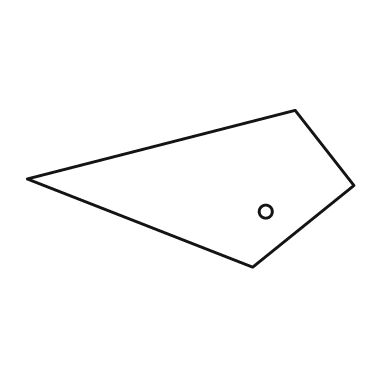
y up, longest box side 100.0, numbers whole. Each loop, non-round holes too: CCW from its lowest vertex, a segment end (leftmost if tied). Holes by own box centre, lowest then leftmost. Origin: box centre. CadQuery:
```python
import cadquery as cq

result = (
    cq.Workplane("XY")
    .moveTo(19.0, -24.0)
    .lineTo(50.0, 1.0)
    .lineTo(32.0, 24.0)
    .lineTo(-50.0, 3.0)
    .close()
    .moveTo(23.0, -7.0)
    .circle(2.0)
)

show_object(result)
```